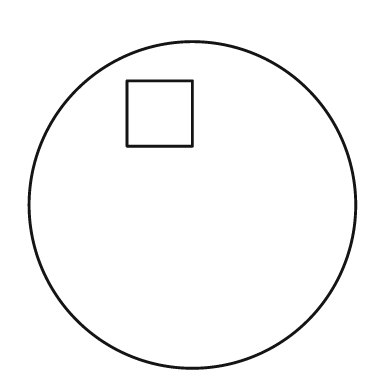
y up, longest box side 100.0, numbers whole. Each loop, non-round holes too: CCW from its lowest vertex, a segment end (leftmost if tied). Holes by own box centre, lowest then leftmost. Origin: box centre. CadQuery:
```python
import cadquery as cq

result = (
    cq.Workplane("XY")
    .moveTo(0.0, 0.0)
    .circle(50.0)
    .moveTo(-20.0, 18.0)
    .lineTo(0.0, 18.0)
    .lineTo(0.0, 38.0)
    .lineTo(-20.0, 38.0)
    .close()
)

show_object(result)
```